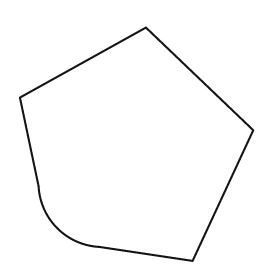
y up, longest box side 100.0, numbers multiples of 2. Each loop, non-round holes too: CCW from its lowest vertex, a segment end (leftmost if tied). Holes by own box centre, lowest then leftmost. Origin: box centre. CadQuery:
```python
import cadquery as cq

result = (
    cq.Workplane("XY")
    .moveTo(24.0, -50.0)
    .lineTo(50.0, 6.0)
    .lineTo(4.0, 50.0)
    .lineTo(-50.0, 20.0)
    .lineTo(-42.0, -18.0)
    .threePointArc((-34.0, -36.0), (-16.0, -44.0))
    .close()
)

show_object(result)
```